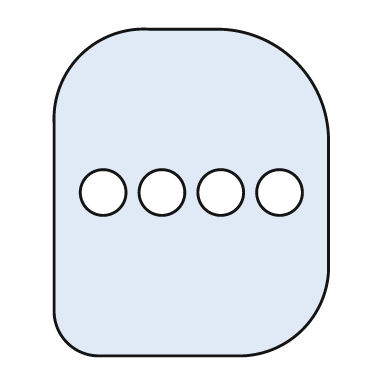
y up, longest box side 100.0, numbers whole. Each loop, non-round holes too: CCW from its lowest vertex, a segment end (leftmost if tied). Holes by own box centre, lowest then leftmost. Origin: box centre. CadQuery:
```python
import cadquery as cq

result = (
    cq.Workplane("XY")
    .moveTo(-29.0, -50.0)
    .lineTo(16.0, -50.0)
    .threePointArc((34.0, -42.0), (42.0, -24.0))
    .lineTo(42.0, 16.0)
    .threePointArc((32.0, 40.0), (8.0, 50.0))
    .lineTo(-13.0, 50.0)
    .threePointArc((-34.0, 42.0), (-42.0, 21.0))
    .lineTo(-42.0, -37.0)
    .threePointArc((-38.0, -46.0), (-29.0, -50.0))
    .close()
    .moveTo(-27.0, 0.0)
    .circle(7.0)
    .moveTo(-9.0, 0.0)
    .circle(7.0)
    .moveTo(9.0, 0.0)
    .circle(7.0)
    .moveTo(27.0, 0.0)
    .circle(7.0)
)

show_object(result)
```